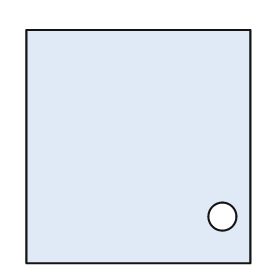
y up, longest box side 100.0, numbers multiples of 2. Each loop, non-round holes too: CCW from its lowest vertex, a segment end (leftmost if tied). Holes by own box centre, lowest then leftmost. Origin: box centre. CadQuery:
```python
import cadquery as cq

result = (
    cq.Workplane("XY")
    .moveTo(-48.0, -50.0)
    .lineTo(48.0, -50.0)
    .lineTo(48.0, 50.0)
    .lineTo(-48.0, 50.0)
    .close()
    .moveTo(36.0, -30.0)
    .circle(6.0)
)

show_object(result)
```